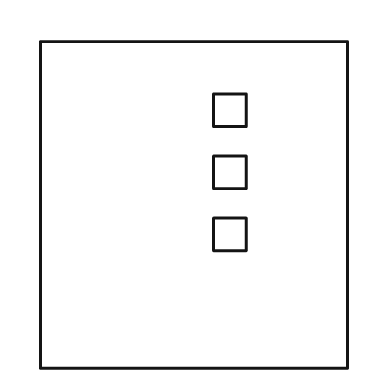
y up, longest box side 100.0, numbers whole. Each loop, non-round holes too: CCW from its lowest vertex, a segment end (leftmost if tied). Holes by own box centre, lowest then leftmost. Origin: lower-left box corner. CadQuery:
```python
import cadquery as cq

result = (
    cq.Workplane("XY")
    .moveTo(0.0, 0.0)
    .lineTo(94.0, 0.0)
    .lineTo(94.0, 100.0)
    .lineTo(0.0, 100.0)
    .close()
    .moveTo(53.0, 36.0)
    .lineTo(63.0, 36.0)
    .lineTo(63.0, 46.0)
    .lineTo(53.0, 46.0)
    .close()
    .moveTo(53.0, 55.0)
    .lineTo(63.0, 55.0)
    .lineTo(63.0, 65.0)
    .lineTo(53.0, 65.0)
    .close()
    .moveTo(53.0, 74.0)
    .lineTo(63.0, 74.0)
    .lineTo(63.0, 84.0)
    .lineTo(53.0, 84.0)
    .close()
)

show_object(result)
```